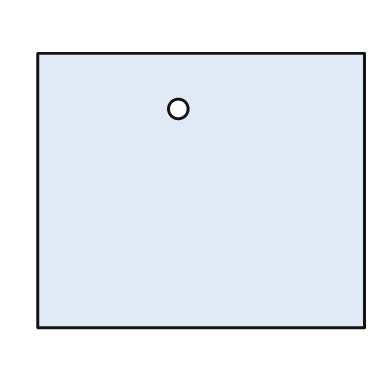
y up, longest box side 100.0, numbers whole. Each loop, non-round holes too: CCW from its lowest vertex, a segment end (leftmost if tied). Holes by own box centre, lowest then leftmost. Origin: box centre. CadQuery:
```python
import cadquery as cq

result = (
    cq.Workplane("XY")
    .moveTo(-50.0, -42.0)
    .lineTo(50.0, -42.0)
    .lineTo(50.0, 42.0)
    .lineTo(-50.0, 42.0)
    .close()
    .moveTo(-7.0, 25.0)
    .circle(3.0)
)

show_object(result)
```